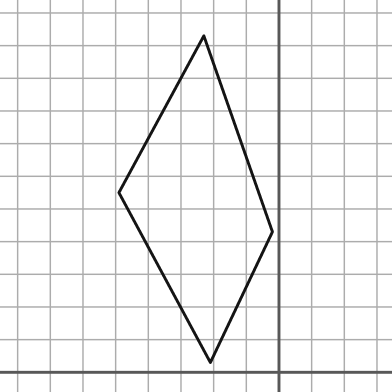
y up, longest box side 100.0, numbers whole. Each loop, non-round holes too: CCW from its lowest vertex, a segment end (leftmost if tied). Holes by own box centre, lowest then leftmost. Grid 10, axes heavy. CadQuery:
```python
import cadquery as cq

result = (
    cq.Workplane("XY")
    .moveTo(-21.0, 3.0)
    .lineTo(-2.0, 43.0)
    .lineTo(-23.0, 103.0)
    .lineTo(-49.0, 55.0)
    .close()
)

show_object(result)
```